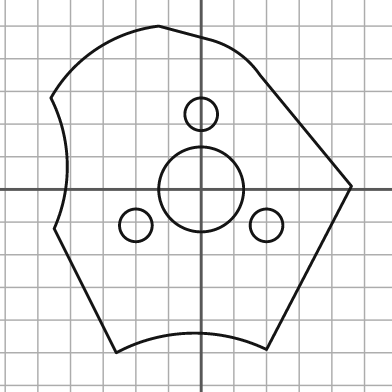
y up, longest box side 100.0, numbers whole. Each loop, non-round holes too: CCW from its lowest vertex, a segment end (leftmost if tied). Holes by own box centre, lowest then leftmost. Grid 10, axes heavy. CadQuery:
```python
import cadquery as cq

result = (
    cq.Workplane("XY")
    .moveTo(-26.0, -50.0)
    .threePointArc((-3.0, -44.0), (20.0, -49.0))
    .lineTo(46.0, 1.0)
    .lineTo(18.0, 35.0)
    .threePointArc((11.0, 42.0), (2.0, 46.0))
    .lineTo(-13.0, 50.0)
    .threePointArc((-32.0, 43.0), (-46.0, 28.0))
    .threePointArc((-41.0, 8.0), (-45.0, -12.0))
    .close()
    .moveTo(-20.0, -11.0)
    .circle(5.0)
    .moveTo(20.0, -11.0)
    .circle(5.0)
    .moveTo(0.0, 0.0)
    .circle(13.0)
    .moveTo(0.0, 23.0)
    .circle(5.0)
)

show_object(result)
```